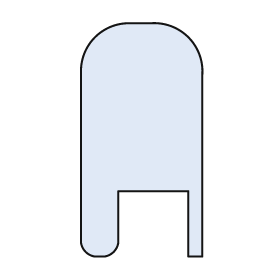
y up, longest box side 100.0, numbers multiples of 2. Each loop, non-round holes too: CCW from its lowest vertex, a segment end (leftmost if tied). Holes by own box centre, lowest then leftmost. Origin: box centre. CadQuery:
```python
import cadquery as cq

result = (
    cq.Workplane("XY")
    .moveTo(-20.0, -50.0)
    .lineTo(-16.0, -50.0)
    .threePointArc((-12.0, -48.0), (-10.0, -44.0))
    .lineTo(-10.0, -22.0)
    .lineTo(20.0, -22.0)
    .lineTo(20.0, -50.0)
    .lineTo(26.0, -50.0)
    .lineTo(26.0, 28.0)
    .threePointArc((20.0, 44.0), (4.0, 50.0))
    .lineTo(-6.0, 50.0)
    .threePointArc((-20.0, 44.0), (-26.0, 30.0))
    .lineTo(-26.0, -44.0)
    .threePointArc((-24.0, -48.0), (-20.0, -50.0))
    .close()
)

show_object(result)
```